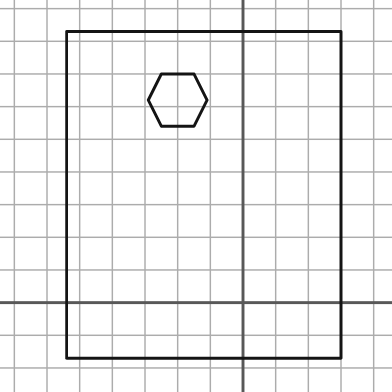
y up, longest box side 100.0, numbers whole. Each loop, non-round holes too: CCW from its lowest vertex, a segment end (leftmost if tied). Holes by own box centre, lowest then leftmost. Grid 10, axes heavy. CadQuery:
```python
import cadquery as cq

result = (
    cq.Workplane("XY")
    .moveTo(-54.0, -17.0)
    .lineTo(30.0, -17.0)
    .lineTo(30.0, 83.0)
    .lineTo(-54.0, 83.0)
    .close()
    .moveTo(-25.0, 54.0)
    .lineTo(-15.0, 54.0)
    .lineTo(-11.0, 62.0)
    .lineTo(-15.0, 70.0)
    .lineTo(-25.0, 70.0)
    .lineTo(-29.0, 62.0)
    .close()
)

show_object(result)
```